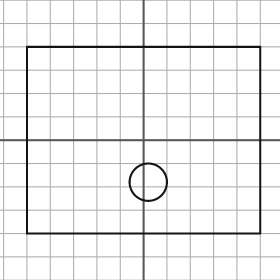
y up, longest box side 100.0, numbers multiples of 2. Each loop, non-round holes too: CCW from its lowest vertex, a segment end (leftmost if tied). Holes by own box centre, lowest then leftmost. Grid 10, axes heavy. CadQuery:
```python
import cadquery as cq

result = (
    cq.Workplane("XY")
    .moveTo(-50.0, -40.0)
    .lineTo(50.0, -40.0)
    .lineTo(50.0, 40.0)
    .lineTo(-50.0, 40.0)
    .close()
    .moveTo(2.0, -18.0)
    .circle(8.0)
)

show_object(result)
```